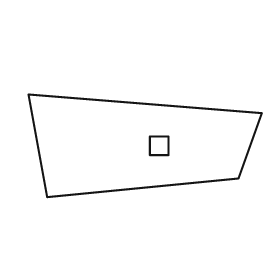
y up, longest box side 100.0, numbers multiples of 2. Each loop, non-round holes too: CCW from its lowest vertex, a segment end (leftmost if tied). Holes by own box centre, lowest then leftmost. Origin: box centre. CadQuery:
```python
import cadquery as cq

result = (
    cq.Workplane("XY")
    .moveTo(-42.0, -22.0)
    .lineTo(40.0, -14.0)
    .lineTo(50.0, 14.0)
    .lineTo(-50.0, 22.0)
    .close()
    .moveTo(2.0, -4.0)
    .lineTo(10.0, -4.0)
    .lineTo(10.0, 4.0)
    .lineTo(2.0, 4.0)
    .close()
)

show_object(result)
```